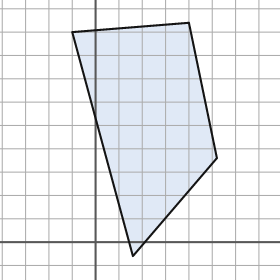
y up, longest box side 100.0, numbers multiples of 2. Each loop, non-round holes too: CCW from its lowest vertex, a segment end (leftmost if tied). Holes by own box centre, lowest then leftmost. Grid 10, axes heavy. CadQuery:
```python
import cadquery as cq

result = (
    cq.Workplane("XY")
    .moveTo(16.0, -6.0)
    .lineTo(52.0, 36.0)
    .lineTo(40.0, 94.0)
    .lineTo(-10.0, 90.0)
    .close()
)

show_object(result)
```